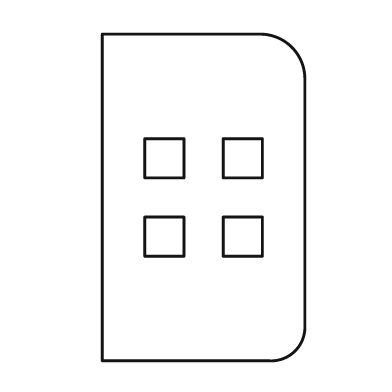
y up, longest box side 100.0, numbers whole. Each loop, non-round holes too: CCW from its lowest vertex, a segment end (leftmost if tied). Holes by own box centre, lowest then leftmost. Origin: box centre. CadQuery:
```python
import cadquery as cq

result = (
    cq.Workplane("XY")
    .moveTo(-31.0, -50.0)
    .lineTo(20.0, -50.0)
    .threePointArc((28.0, -47.0), (31.0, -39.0))
    .lineTo(31.0, 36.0)
    .threePointArc((27.0, 46.0), (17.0, 50.0))
    .lineTo(-31.0, 50.0)
    .close()
    .moveTo(-18.0, -18.0)
    .lineTo(-6.0, -18.0)
    .lineTo(-6.0, -6.0)
    .lineTo(-18.0, -6.0)
    .close()
    .moveTo(6.0, -18.0)
    .lineTo(18.0, -18.0)
    .lineTo(18.0, -6.0)
    .lineTo(6.0, -6.0)
    .close()
    .moveTo(-18.0, 6.0)
    .lineTo(-6.0, 6.0)
    .lineTo(-6.0, 18.0)
    .lineTo(-18.0, 18.0)
    .close()
    .moveTo(6.0, 6.0)
    .lineTo(18.0, 6.0)
    .lineTo(18.0, 18.0)
    .lineTo(6.0, 18.0)
    .close()
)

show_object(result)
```